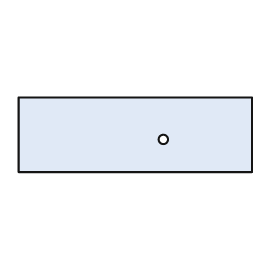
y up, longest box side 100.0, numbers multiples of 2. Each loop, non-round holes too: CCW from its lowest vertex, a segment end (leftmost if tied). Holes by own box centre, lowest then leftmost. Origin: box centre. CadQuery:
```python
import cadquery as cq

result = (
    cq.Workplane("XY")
    .moveTo(-50.0, -16.0)
    .lineTo(50.0, -16.0)
    .lineTo(50.0, 16.0)
    .lineTo(-50.0, 16.0)
    .close()
    .moveTo(12.0, -2.0)
    .circle(2.0)
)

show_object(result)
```